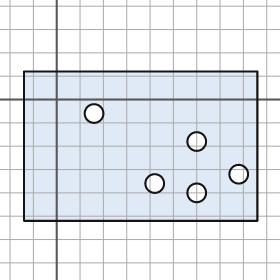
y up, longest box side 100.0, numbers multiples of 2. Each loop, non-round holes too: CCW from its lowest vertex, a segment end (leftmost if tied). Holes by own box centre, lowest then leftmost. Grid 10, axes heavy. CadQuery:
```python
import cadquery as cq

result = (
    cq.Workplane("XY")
    .moveTo(-14.0, -52.0)
    .lineTo(86.0, -52.0)
    .lineTo(86.0, 12.0)
    .lineTo(-14.0, 12.0)
    .close()
    .moveTo(60.0, -40.0)
    .circle(4.0)
    .moveTo(42.0, -36.0)
    .circle(4.0)
    .moveTo(78.0, -32.0)
    .circle(4.0)
    .moveTo(60.0, -18.0)
    .circle(4.0)
    .moveTo(16.0, -6.0)
    .circle(4.0)
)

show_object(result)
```